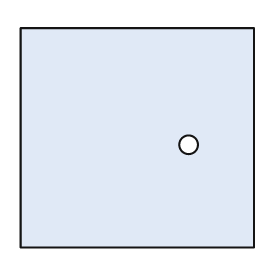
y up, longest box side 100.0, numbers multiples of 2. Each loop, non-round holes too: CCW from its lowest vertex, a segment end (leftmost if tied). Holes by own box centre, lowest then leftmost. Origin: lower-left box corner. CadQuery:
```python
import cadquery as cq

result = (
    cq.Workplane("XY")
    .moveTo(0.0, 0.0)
    .lineTo(100.0, 0.0)
    .lineTo(100.0, 94.0)
    .lineTo(0.0, 94.0)
    .close()
    .moveTo(72.0, 44.0)
    .circle(4.0)
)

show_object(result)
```